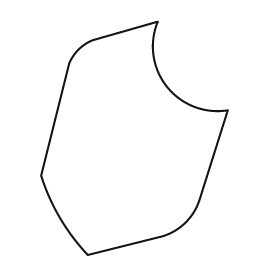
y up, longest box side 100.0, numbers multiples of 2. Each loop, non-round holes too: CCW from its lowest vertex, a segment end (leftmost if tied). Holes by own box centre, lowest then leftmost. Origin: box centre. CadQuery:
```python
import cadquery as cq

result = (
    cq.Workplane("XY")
    .moveTo(-20.0, -50.0)
    .lineTo(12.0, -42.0)
    .threePointArc((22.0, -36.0), (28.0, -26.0))
    .lineTo(40.0, 12.0)
    .threePointArc((14.0, 22.0), (10.0, 50.0))
    .lineTo(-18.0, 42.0)
    .threePointArc((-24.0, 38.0), (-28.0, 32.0))
    .lineTo(-40.0, -16.0)
    .threePointArc((-32.0, -34.0), (-20.0, -50.0))
    .close()
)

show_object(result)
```